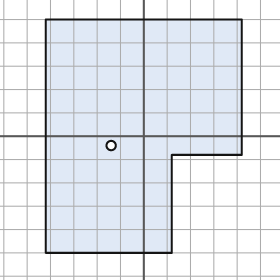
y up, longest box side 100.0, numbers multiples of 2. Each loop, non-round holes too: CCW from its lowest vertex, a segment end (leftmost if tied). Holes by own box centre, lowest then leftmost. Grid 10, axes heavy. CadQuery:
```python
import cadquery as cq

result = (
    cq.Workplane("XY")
    .moveTo(-42.0, -50.0)
    .lineTo(12.0, -50.0)
    .lineTo(12.0, -8.0)
    .lineTo(42.0, -8.0)
    .lineTo(42.0, 50.0)
    .lineTo(-42.0, 50.0)
    .close()
    .moveTo(-14.0, -4.0)
    .circle(2.0)
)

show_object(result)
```